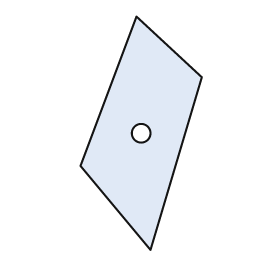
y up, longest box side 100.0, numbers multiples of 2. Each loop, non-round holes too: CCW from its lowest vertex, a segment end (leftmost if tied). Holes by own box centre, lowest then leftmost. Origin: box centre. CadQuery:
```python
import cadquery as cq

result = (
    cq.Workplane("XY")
    .moveTo(4.0, -50.0)
    .lineTo(26.0, 24.0)
    .lineTo(-2.0, 50.0)
    .lineTo(-26.0, -14.0)
    .close()
    .moveTo(0.0, 0.0)
    .circle(4.0)
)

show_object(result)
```